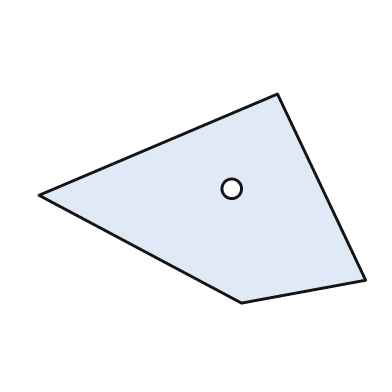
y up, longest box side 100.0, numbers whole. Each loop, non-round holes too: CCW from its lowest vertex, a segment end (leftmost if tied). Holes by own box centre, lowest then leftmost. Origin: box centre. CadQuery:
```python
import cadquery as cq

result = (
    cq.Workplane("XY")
    .moveTo(12.0, -32.0)
    .lineTo(50.0, -25.0)
    .lineTo(23.0, 32.0)
    .lineTo(-50.0, 1.0)
    .close()
    .moveTo(9.0, 3.0)
    .circle(3.0)
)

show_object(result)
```